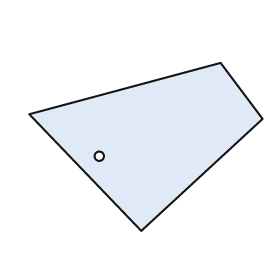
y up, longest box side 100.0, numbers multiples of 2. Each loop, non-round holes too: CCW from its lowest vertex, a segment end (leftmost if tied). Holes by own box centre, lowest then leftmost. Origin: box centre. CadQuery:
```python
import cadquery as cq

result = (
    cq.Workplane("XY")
    .moveTo(-2.0, -36.0)
    .lineTo(50.0, 12.0)
    .lineTo(32.0, 36.0)
    .lineTo(-50.0, 14.0)
    .close()
    .moveTo(-20.0, -4.0)
    .circle(2.0)
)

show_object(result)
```